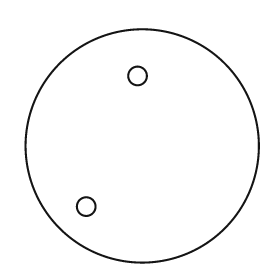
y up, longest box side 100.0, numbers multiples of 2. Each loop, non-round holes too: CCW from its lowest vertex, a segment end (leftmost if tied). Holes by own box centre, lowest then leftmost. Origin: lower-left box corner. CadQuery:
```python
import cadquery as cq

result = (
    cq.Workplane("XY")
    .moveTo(50.0, 50.0)
    .circle(50.0)
    .moveTo(26.0, 24.0)
    .circle(4.0)
    .moveTo(48.0, 80.0)
    .circle(4.0)
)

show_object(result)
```